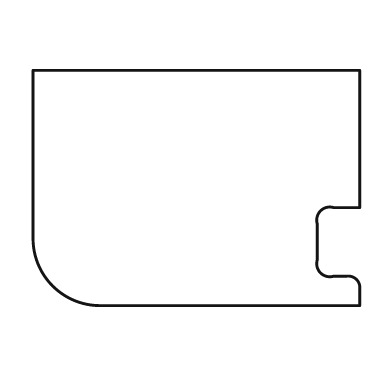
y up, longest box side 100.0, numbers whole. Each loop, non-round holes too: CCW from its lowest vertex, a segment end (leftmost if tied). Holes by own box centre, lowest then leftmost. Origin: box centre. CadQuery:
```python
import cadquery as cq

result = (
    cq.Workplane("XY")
    .moveTo(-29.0, -36.0)
    .lineTo(50.0, -36.0)
    .lineTo(50.0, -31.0)
    .threePointArc((49.0, -28.0), (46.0, -27.0))
    .lineTo(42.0, -27.0)
    .threePointArc((38.0, -26.0), (37.0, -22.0))
    .lineTo(37.0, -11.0)
    .threePointArc((38.0, -7.0), (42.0, -6.0))
    .lineTo(50.0, -6.0)
    .lineTo(50.0, 36.0)
    .lineTo(-50.0, 36.0)
    .lineTo(-50.0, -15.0)
    .threePointArc((-44.0, -30.0), (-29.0, -36.0))
    .close()
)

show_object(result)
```